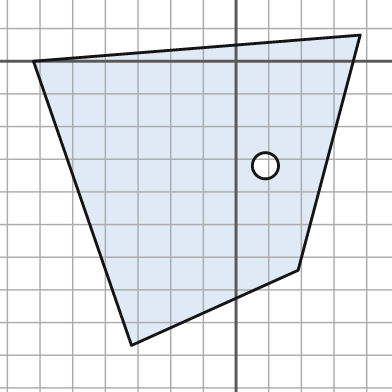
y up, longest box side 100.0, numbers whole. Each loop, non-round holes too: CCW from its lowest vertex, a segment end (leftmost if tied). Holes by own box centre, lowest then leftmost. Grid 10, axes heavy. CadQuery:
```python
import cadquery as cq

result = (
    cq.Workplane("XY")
    .moveTo(-32.0, -87.0)
    .lineTo(19.0, -64.0)
    .lineTo(38.0, 8.0)
    .lineTo(-62.0, 0.0)
    .close()
    .moveTo(9.0, -32.0)
    .circle(4.0)
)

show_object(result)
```